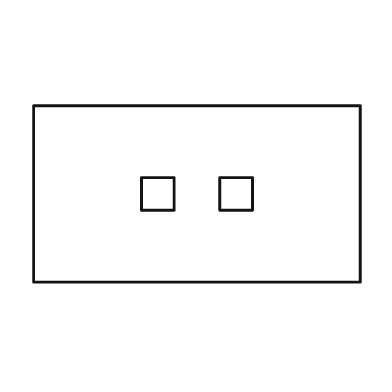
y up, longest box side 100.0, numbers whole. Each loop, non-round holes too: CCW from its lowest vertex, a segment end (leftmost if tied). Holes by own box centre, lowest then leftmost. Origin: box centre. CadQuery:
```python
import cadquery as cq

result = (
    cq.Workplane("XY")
    .moveTo(-50.0, -27.0)
    .lineTo(50.0, -27.0)
    .lineTo(50.0, 27.0)
    .lineTo(-50.0, 27.0)
    .close()
    .moveTo(-17.0, -5.0)
    .lineTo(-7.0, -5.0)
    .lineTo(-7.0, 5.0)
    .lineTo(-17.0, 5.0)
    .close()
    .moveTo(7.0, -5.0)
    .lineTo(17.0, -5.0)
    .lineTo(17.0, 5.0)
    .lineTo(7.0, 5.0)
    .close()
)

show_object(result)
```